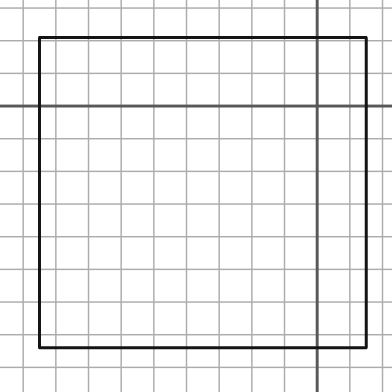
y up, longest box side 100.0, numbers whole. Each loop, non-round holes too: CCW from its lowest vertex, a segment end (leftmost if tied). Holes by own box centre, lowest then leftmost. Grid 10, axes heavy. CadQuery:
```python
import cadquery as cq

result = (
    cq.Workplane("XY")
    .moveTo(-85.0, -74.0)
    .lineTo(15.0, -74.0)
    .lineTo(15.0, 21.0)
    .lineTo(-85.0, 21.0)
    .close()
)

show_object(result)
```